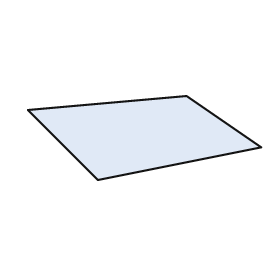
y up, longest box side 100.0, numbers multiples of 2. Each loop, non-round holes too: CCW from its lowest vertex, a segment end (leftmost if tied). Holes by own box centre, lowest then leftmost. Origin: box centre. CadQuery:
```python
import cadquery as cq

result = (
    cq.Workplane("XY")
    .moveTo(-20.0, -18.0)
    .lineTo(50.0, -4.0)
    .lineTo(18.0, 18.0)
    .lineTo(-50.0, 12.0)
    .close()
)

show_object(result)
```